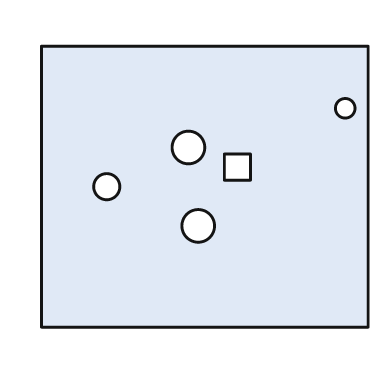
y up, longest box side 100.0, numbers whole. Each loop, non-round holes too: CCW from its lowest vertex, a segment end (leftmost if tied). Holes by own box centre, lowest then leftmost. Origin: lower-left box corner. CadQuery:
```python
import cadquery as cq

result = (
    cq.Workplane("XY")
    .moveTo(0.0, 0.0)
    .lineTo(100.0, 0.0)
    .lineTo(100.0, 86.0)
    .lineTo(0.0, 86.0)
    .close()
    .moveTo(48.0, 31.0)
    .circle(5.0)
    .moveTo(20.0, 43.0)
    .circle(4.0)
    .moveTo(56.0, 45.0)
    .lineTo(64.0, 45.0)
    .lineTo(64.0, 53.0)
    .lineTo(56.0, 53.0)
    .close()
    .moveTo(45.0, 55.0)
    .circle(5.0)
    .moveTo(93.0, 67.0)
    .circle(3.0)
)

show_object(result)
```